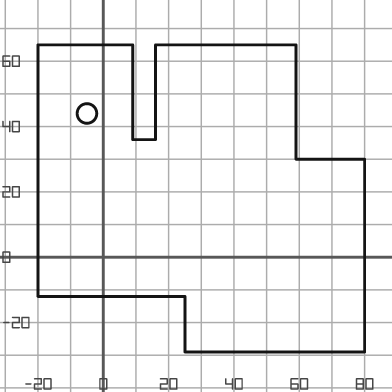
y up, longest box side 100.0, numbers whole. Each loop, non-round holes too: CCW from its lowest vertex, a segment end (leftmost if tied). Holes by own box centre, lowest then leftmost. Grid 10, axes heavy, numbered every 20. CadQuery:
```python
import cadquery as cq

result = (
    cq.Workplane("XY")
    .moveTo(25.0, -29.0)
    .lineTo(80.0, -29.0)
    .lineTo(80.0, 30.0)
    .lineTo(59.0, 30.0)
    .lineTo(59.0, 65.0)
    .lineTo(16.0, 65.0)
    .lineTo(16.0, 36.0)
    .lineTo(9.0, 36.0)
    .lineTo(9.0, 65.0)
    .lineTo(-20.0, 65.0)
    .lineTo(-20.0, -12.0)
    .lineTo(25.0, -12.0)
    .close()
    .moveTo(-5.0, 44.0)
    .circle(3.0)
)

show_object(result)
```